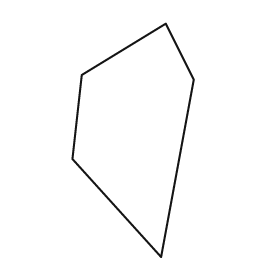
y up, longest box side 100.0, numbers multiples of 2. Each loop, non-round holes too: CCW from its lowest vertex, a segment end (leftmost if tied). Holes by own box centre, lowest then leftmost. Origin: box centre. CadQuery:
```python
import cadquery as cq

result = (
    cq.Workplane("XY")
    .moveTo(12.0, -50.0)
    .lineTo(26.0, 26.0)
    .lineTo(14.0, 50.0)
    .lineTo(-22.0, 28.0)
    .lineTo(-26.0, -8.0)
    .close()
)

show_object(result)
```